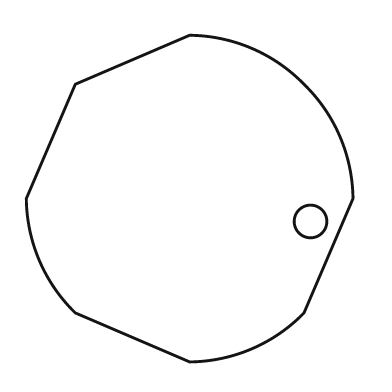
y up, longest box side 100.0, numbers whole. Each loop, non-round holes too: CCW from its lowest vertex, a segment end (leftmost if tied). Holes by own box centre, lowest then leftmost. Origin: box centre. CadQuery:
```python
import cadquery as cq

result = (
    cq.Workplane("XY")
    .moveTo(0.0, -50.0)
    .threePointArc((19.0, -46.0), (35.0, -35.0))
    .lineTo(50.0, 0.0)
    .threePointArc((46.0, 19.0), (35.0, 35.0))
    .threePointArc((19.0, 46.0), (0.0, 50.0))
    .lineTo(-35.0, 35.0)
    .lineTo(-50.0, 0.0)
    .threePointArc((-46.0, -19.0), (-35.0, -35.0))
    .close()
    .moveTo(37.0, -7.0)
    .circle(5.0)
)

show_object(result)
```